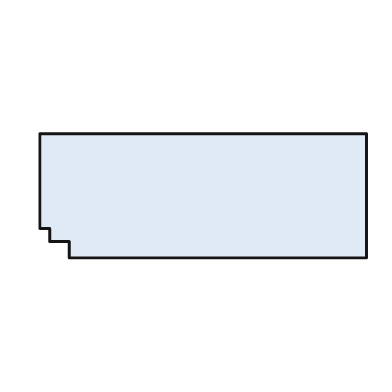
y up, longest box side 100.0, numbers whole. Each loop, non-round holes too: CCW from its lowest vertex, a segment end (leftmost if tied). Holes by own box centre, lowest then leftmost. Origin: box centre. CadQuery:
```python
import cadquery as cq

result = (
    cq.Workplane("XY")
    .moveTo(-41.0, -19.0)
    .lineTo(50.0, -19.0)
    .lineTo(50.0, 19.0)
    .lineTo(-50.0, 19.0)
    .lineTo(-50.0, -10.0)
    .lineTo(-47.0, -10.0)
    .lineTo(-47.0, -14.0)
    .lineTo(-41.0, -14.0)
    .close()
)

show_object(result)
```